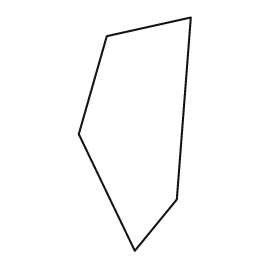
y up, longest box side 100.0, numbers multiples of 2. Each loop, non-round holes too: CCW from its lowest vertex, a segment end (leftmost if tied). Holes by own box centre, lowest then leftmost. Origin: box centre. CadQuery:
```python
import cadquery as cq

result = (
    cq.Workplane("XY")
    .moveTo(0.0, -50.0)
    .lineTo(18.0, -28.0)
    .lineTo(24.0, 50.0)
    .lineTo(-12.0, 42.0)
    .lineTo(-24.0, 0.0)
    .close()
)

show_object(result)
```